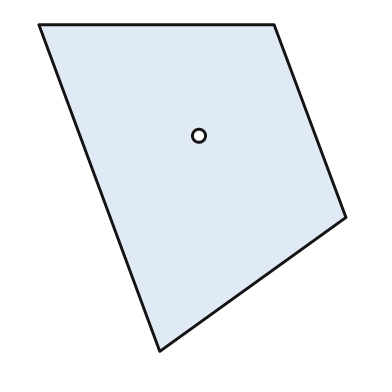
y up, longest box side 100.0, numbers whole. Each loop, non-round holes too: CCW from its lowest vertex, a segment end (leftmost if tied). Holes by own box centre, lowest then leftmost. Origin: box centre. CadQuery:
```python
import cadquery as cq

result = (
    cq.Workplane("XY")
    .moveTo(-10.0, -50.0)
    .lineTo(47.0, -9.0)
    .lineTo(25.0, 50.0)
    .lineTo(-47.0, 50.0)
    .close()
    .moveTo(2.0, 16.0)
    .circle(2.0)
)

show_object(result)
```